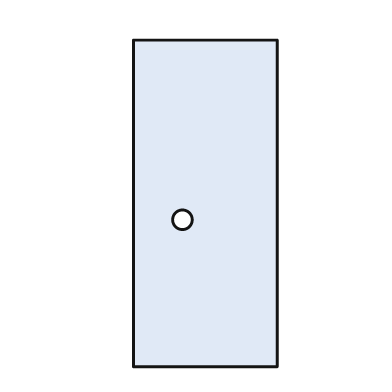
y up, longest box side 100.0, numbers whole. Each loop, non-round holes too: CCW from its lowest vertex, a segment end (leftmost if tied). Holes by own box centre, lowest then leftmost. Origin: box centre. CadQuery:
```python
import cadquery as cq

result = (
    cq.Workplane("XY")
    .moveTo(-22.0, -50.0)
    .lineTo(22.0, -50.0)
    .lineTo(22.0, 50.0)
    .lineTo(-22.0, 50.0)
    .close()
    .moveTo(-7.0, -5.0)
    .circle(3.0)
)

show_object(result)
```